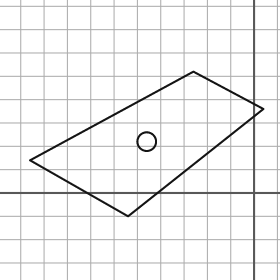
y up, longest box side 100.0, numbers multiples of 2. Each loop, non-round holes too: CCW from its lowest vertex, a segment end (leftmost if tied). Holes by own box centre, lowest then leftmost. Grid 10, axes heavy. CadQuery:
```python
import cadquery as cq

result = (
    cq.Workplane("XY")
    .moveTo(-54.0, -10.0)
    .lineTo(4.0, 36.0)
    .lineTo(-26.0, 52.0)
    .lineTo(-96.0, 14.0)
    .close()
    .moveTo(-46.0, 22.0)
    .circle(4.0)
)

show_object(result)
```